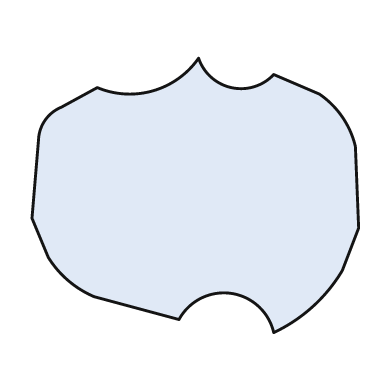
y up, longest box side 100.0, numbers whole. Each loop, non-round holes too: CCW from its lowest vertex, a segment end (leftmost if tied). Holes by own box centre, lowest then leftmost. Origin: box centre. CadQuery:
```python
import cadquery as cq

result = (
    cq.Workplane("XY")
    .moveTo(24.0, -42.0)
    .threePointArc((36.0, -34.0), (45.0, -23.0))
    .lineTo(50.0, -10.0)
    .lineTo(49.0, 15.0)
    .threePointArc((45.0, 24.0), (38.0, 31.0))
    .lineTo(24.0, 37.0)
    .threePointArc((11.0, 33.0), (1.0, 42.0))
    .threePointArc((-13.0, 32.0), (-30.0, 33.0))
    .lineTo(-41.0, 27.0)
    .threePointArc((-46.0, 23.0), (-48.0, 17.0))
    .lineTo(-50.0, -7.0)
    .lineTo(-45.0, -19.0)
    .threePointArc((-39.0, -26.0), (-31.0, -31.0))
    .lineTo(-5.0, -38.0)
    .threePointArc((11.0, -30.0), (24.0, -42.0))
    .close()
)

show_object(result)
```